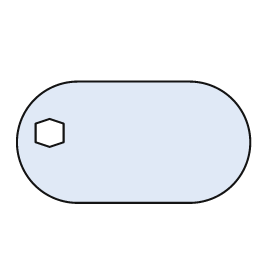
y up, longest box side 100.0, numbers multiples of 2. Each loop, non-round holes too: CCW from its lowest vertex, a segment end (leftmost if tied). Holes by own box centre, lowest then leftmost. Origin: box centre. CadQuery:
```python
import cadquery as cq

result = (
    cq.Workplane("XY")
    .moveTo(-24.0, -26.0)
    .lineTo(24.0, -26.0)
    .threePointArc((50.0, 0.0), (24.0, 26.0))
    .lineTo(-24.0, 26.0)
    .threePointArc((-50.0, 0.0), (-24.0, -26.0))
    .close()
    .moveTo(-36.0, -2.0)
    .lineTo(-30.0, 0.0)
    .lineTo(-30.0, 8.0)
    .lineTo(-36.0, 10.0)
    .lineTo(-42.0, 8.0)
    .lineTo(-42.0, 0.0)
    .close()
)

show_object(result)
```